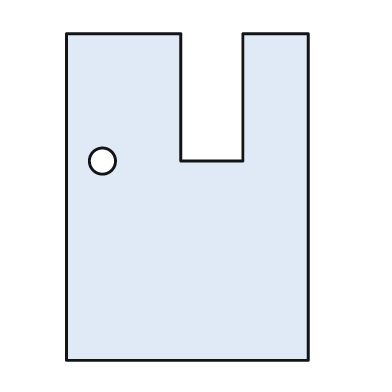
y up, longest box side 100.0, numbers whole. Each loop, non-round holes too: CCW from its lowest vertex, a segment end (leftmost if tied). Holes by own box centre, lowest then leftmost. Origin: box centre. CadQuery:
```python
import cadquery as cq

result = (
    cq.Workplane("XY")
    .moveTo(-37.0, -50.0)
    .lineTo(37.0, -50.0)
    .lineTo(37.0, 50.0)
    .lineTo(17.0, 50.0)
    .lineTo(17.0, 11.0)
    .lineTo(-2.0, 11.0)
    .lineTo(-2.0, 50.0)
    .lineTo(-37.0, 50.0)
    .close()
    .moveTo(-26.0, 11.0)
    .circle(4.0)
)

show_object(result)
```